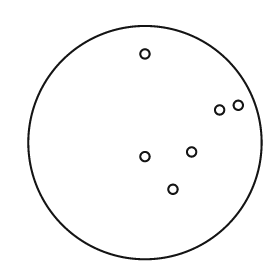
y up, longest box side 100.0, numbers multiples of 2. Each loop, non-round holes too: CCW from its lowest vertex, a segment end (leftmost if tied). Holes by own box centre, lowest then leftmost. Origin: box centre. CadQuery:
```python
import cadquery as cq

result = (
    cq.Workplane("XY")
    .moveTo(0.0, 0.0)
    .circle(50.0)
    .moveTo(12.0, -20.0)
    .circle(2.0)
    .moveTo(0.0, -6.0)
    .circle(2.0)
    .moveTo(20.0, -4.0)
    .circle(2.0)
    .moveTo(32.0, 14.0)
    .circle(2.0)
    .moveTo(40.0, 16.0)
    .circle(2.0)
    .moveTo(0.0, 38.0)
    .circle(2.0)
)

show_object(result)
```